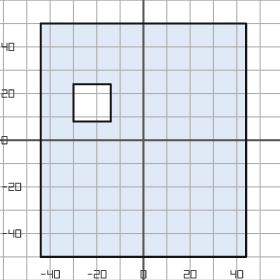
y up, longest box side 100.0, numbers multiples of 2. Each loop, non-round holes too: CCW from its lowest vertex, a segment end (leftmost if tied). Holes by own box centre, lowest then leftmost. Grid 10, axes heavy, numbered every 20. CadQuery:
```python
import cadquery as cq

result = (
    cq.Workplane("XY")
    .moveTo(-44.0, -50.0)
    .lineTo(44.0, -50.0)
    .lineTo(44.0, 50.0)
    .lineTo(-44.0, 50.0)
    .close()
    .moveTo(-30.0, 8.0)
    .lineTo(-14.0, 8.0)
    .lineTo(-14.0, 24.0)
    .lineTo(-30.0, 24.0)
    .close()
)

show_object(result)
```